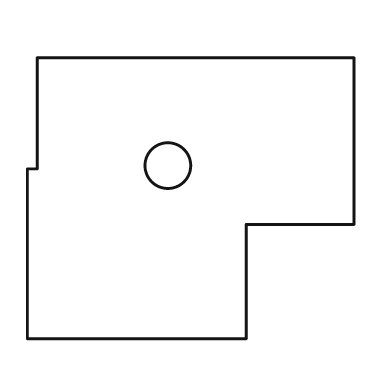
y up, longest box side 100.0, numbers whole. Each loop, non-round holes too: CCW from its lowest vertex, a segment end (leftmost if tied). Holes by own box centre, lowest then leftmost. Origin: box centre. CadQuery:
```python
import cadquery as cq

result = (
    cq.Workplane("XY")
    .moveTo(-50.0, -43.0)
    .lineTo(17.0, -43.0)
    .lineTo(17.0, -8.0)
    .lineTo(50.0, -8.0)
    .lineTo(50.0, 43.0)
    .lineTo(-47.0, 43.0)
    .lineTo(-47.0, 9.0)
    .lineTo(-50.0, 9.0)
    .close()
    .moveTo(-7.0, 10.0)
    .circle(7.0)
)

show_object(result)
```